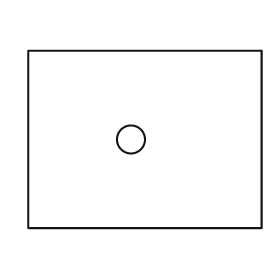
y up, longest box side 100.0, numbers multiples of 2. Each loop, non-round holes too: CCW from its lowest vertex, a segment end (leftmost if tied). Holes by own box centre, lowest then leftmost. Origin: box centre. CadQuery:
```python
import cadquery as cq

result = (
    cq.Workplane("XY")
    .moveTo(-50.0, -38.0)
    .lineTo(50.0, -38.0)
    .lineTo(50.0, 38.0)
    .lineTo(-50.0, 38.0)
    .close()
    .moveTo(-6.0, 0.0)
    .circle(6.0)
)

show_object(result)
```